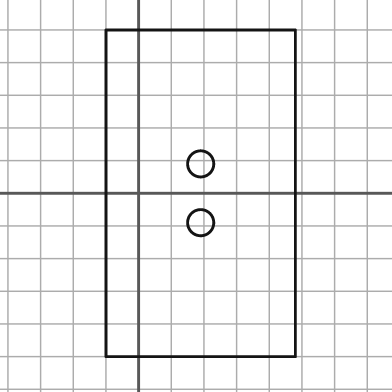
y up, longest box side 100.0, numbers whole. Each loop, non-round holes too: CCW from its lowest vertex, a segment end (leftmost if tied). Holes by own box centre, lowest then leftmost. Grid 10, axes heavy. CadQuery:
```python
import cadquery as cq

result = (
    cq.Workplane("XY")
    .moveTo(-10.0, -50.0)
    .lineTo(48.0, -50.0)
    .lineTo(48.0, 50.0)
    .lineTo(-10.0, 50.0)
    .close()
    .moveTo(19.0, -9.0)
    .circle(4.0)
    .moveTo(19.0, 9.0)
    .circle(4.0)
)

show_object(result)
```